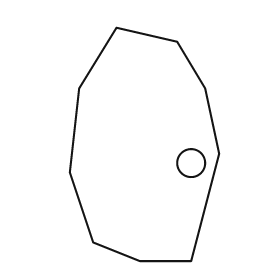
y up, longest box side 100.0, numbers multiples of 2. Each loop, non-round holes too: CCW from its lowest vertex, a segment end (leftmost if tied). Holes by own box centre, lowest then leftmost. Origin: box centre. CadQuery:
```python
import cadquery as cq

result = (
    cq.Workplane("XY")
    .moveTo(-2.0, -50.0)
    .lineTo(20.0, -50.0)
    .lineTo(32.0, -4.0)
    .lineTo(26.0, 24.0)
    .lineTo(14.0, 44.0)
    .lineTo(-12.0, 50.0)
    .lineTo(-28.0, 24.0)
    .lineTo(-32.0, -12.0)
    .lineTo(-22.0, -42.0)
    .close()
    .moveTo(20.0, -8.0)
    .circle(6.0)
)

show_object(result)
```